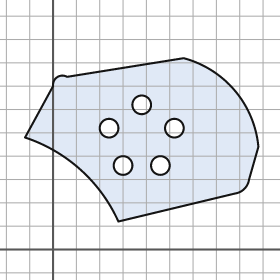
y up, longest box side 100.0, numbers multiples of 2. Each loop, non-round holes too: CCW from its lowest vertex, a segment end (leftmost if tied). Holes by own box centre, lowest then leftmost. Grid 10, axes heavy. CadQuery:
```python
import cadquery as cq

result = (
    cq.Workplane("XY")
    .moveTo(28.0, 12.0)
    .lineTo(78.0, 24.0)
    .threePointArc((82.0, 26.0), (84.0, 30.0))
    .lineTo(88.0, 44.0)
    .threePointArc((78.0, 68.0), (56.0, 82.0))
    .lineTo(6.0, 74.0)
    .threePointArc((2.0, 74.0), (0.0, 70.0))
    .lineTo(-12.0, 48.0)
    .threePointArc((12.0, 34.0), (28.0, 12.0))
    .close()
    .moveTo(30.0, 36.0)
    .circle(4.0)
    .moveTo(46.0, 36.0)
    .circle(4.0)
    .moveTo(24.0, 52.0)
    .circle(4.0)
    .moveTo(52.0, 52.0)
    .circle(4.0)
    .moveTo(38.0, 62.0)
    .circle(4.0)
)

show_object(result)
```